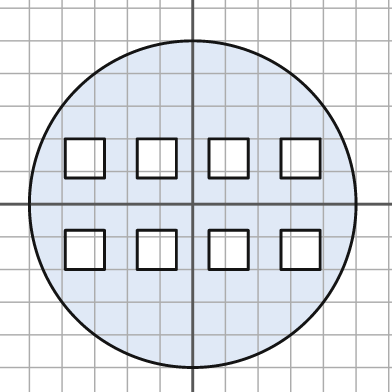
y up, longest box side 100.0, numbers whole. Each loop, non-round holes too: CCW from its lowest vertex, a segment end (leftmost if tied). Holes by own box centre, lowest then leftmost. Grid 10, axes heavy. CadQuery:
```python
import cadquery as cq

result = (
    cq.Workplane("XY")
    .moveTo(0.0, 0.0)
    .circle(50.0)
    .moveTo(-39.0, -20.0)
    .lineTo(-27.0, -20.0)
    .lineTo(-27.0, -8.0)
    .lineTo(-39.0, -8.0)
    .close()
    .moveTo(-17.0, -20.0)
    .lineTo(-5.0, -20.0)
    .lineTo(-5.0, -8.0)
    .lineTo(-17.0, -8.0)
    .close()
    .moveTo(5.0, -20.0)
    .lineTo(17.0, -20.0)
    .lineTo(17.0, -8.0)
    .lineTo(5.0, -8.0)
    .close()
    .moveTo(27.0, -20.0)
    .lineTo(39.0, -20.0)
    .lineTo(39.0, -8.0)
    .lineTo(27.0, -8.0)
    .close()
    .moveTo(-39.0, 8.0)
    .lineTo(-27.0, 8.0)
    .lineTo(-27.0, 20.0)
    .lineTo(-39.0, 20.0)
    .close()
    .moveTo(-17.0, 8.0)
    .lineTo(-5.0, 8.0)
    .lineTo(-5.0, 20.0)
    .lineTo(-17.0, 20.0)
    .close()
    .moveTo(5.0, 8.0)
    .lineTo(17.0, 8.0)
    .lineTo(17.0, 20.0)
    .lineTo(5.0, 20.0)
    .close()
    .moveTo(27.0, 8.0)
    .lineTo(39.0, 8.0)
    .lineTo(39.0, 20.0)
    .lineTo(27.0, 20.0)
    .close()
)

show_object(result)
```